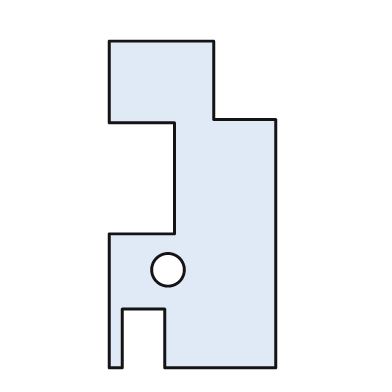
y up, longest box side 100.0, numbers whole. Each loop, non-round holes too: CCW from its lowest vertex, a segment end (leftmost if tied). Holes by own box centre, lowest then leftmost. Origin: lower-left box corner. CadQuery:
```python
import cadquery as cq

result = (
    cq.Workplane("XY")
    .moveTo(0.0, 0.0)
    .lineTo(4.0, 0.0)
    .lineTo(4.0, 18.0)
    .lineTo(17.0, 18.0)
    .lineTo(17.0, 0.0)
    .lineTo(51.0, 0.0)
    .lineTo(51.0, 76.0)
    .lineTo(32.0, 76.0)
    .lineTo(32.0, 100.0)
    .lineTo(0.0, 100.0)
    .lineTo(0.0, 75.0)
    .lineTo(20.0, 75.0)
    .lineTo(20.0, 41.0)
    .lineTo(0.0, 41.0)
    .close()
    .moveTo(18.0, 30.0)
    .circle(5.0)
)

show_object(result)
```